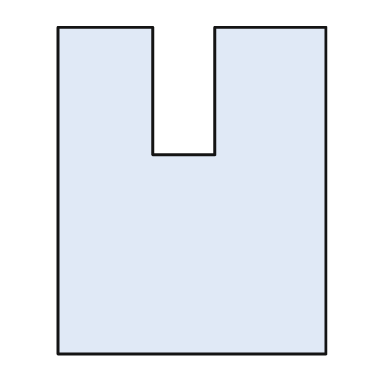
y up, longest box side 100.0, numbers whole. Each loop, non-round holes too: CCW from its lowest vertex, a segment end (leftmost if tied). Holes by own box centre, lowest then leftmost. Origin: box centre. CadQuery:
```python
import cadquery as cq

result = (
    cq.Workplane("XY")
    .moveTo(-41.0, -50.0)
    .lineTo(41.0, -50.0)
    .lineTo(41.0, 50.0)
    .lineTo(7.0, 50.0)
    .lineTo(7.0, 11.0)
    .lineTo(-12.0, 11.0)
    .lineTo(-12.0, 50.0)
    .lineTo(-41.0, 50.0)
    .close()
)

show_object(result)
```